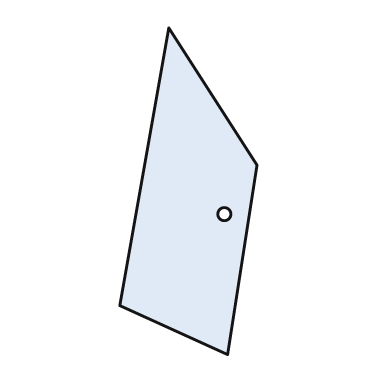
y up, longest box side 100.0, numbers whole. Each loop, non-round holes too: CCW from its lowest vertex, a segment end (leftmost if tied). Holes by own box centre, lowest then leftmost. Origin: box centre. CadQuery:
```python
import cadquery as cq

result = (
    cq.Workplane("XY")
    .moveTo(12.0, -50.0)
    .lineTo(21.0, 8.0)
    .lineTo(-6.0, 50.0)
    .lineTo(-21.0, -35.0)
    .close()
    .moveTo(11.0, -7.0)
    .circle(2.0)
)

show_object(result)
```